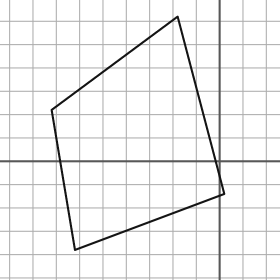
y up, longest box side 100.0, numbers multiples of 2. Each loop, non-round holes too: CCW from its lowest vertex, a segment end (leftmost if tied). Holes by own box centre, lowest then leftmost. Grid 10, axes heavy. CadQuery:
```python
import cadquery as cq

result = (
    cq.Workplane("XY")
    .moveTo(-62.0, -38.0)
    .lineTo(2.0, -14.0)
    .lineTo(-18.0, 62.0)
    .lineTo(-72.0, 22.0)
    .close()
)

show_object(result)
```